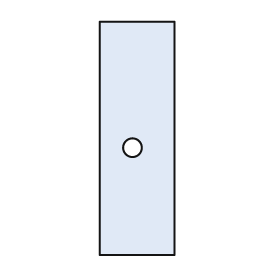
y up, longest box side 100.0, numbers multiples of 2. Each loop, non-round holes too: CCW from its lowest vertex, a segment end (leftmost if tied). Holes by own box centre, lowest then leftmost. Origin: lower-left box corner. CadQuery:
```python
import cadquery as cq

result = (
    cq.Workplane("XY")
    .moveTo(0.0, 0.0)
    .lineTo(32.0, 0.0)
    .lineTo(32.0, 100.0)
    .lineTo(0.0, 100.0)
    .close()
    .moveTo(14.0, 46.0)
    .circle(4.0)
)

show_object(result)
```